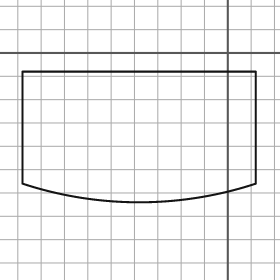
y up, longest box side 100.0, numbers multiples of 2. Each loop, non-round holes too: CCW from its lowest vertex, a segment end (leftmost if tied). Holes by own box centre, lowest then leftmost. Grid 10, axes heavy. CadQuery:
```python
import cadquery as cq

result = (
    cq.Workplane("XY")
    .moveTo(-88.0, -56.0)
    .threePointArc((-38.0, -64.0), (12.0, -56.0))
    .lineTo(12.0, -8.0)
    .lineTo(-88.0, -8.0)
    .close()
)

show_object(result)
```